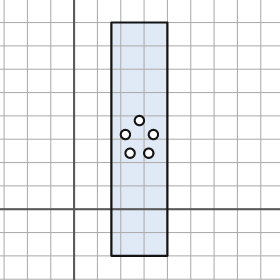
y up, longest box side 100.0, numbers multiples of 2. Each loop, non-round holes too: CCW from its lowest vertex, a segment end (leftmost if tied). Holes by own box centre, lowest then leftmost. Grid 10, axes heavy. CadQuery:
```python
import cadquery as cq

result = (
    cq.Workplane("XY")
    .moveTo(16.0, -20.0)
    .lineTo(40.0, -20.0)
    .lineTo(40.0, 80.0)
    .lineTo(16.0, 80.0)
    .close()
    .moveTo(24.0, 24.0)
    .circle(2.0)
    .moveTo(32.0, 24.0)
    .circle(2.0)
    .moveTo(22.0, 32.0)
    .circle(2.0)
    .moveTo(34.0, 32.0)
    .circle(2.0)
    .moveTo(28.0, 38.0)
    .circle(2.0)
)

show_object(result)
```